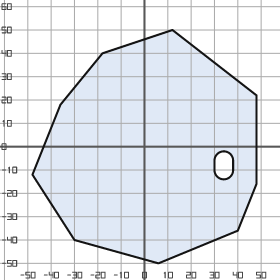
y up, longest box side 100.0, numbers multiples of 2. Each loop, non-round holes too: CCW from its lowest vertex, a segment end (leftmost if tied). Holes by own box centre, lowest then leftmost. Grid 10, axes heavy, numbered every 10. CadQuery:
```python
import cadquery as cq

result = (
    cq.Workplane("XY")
    .moveTo(6.0, -50.0)
    .lineTo(40.0, -36.0)
    .lineTo(48.0, -16.0)
    .lineTo(48.0, 22.0)
    .lineTo(12.0, 50.0)
    .lineTo(-18.0, 40.0)
    .lineTo(-36.0, 18.0)
    .lineTo(-48.0, -12.0)
    .lineTo(-30.0, -40.0)
    .close()
    .moveTo(30.0, -10.0)
    .threePointArc((34.0, -14.0), (38.0, -10.0))
    .lineTo(38.0, -6.0)
    .threePointArc((34.0, -2.0), (30.0, -6.0))
    .close()
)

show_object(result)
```